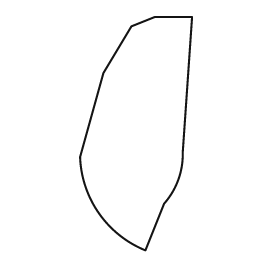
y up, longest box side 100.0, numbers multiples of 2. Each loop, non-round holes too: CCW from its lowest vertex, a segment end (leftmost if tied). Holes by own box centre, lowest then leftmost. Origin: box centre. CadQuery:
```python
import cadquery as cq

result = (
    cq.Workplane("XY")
    .moveTo(4.0, -50.0)
    .lineTo(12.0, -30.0)
    .threePointArc((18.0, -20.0), (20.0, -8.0))
    .lineTo(24.0, 50.0)
    .lineTo(8.0, 50.0)
    .lineTo(-2.0, 46.0)
    .lineTo(-14.0, 26.0)
    .lineTo(-24.0, -10.0)
    .threePointArc((-16.0, -34.0), (4.0, -50.0))
    .close()
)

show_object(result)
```